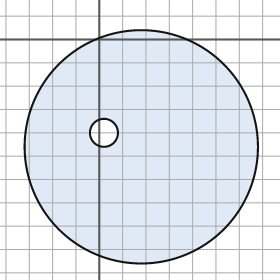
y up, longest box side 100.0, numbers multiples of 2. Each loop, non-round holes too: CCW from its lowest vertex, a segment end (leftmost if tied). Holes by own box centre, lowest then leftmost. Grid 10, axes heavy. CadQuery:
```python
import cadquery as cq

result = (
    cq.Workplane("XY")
    .moveTo(18.0, -46.0)
    .circle(50.0)
    .moveTo(2.0, -40.0)
    .circle(6.0)
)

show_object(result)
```